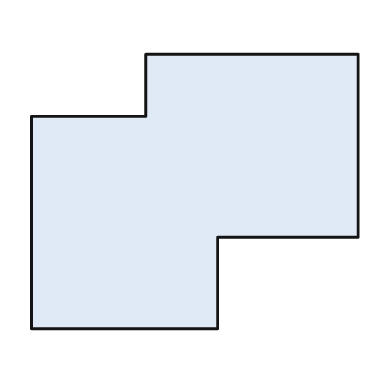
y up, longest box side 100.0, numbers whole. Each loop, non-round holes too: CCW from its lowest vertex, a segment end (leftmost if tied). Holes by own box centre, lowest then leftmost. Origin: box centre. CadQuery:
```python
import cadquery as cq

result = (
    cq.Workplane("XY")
    .moveTo(-50.0, -42.0)
    .lineTo(7.0, -42.0)
    .lineTo(7.0, -14.0)
    .lineTo(50.0, -14.0)
    .lineTo(50.0, 42.0)
    .lineTo(-15.0, 42.0)
    .lineTo(-15.0, 23.0)
    .lineTo(-50.0, 23.0)
    .close()
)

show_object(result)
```